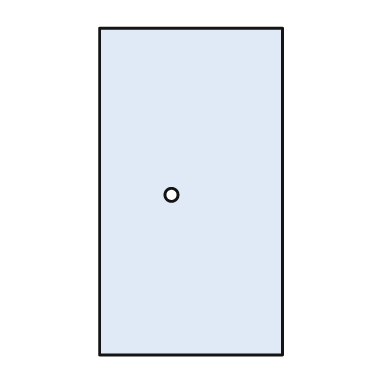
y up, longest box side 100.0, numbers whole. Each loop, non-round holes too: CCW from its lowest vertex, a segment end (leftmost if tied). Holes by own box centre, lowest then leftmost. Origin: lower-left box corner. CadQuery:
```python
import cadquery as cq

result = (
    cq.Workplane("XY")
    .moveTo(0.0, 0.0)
    .lineTo(56.0, 0.0)
    .lineTo(56.0, 100.0)
    .lineTo(0.0, 100.0)
    .close()
    .moveTo(22.0, 49.0)
    .circle(2.0)
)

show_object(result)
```